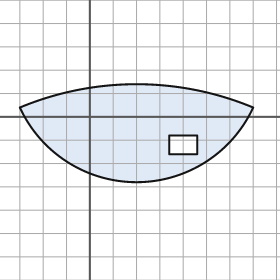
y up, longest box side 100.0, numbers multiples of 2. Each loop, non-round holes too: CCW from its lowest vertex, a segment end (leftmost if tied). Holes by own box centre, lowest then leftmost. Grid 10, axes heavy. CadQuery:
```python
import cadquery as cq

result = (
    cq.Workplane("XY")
    .moveTo(-30.0, 4.0)
    .threePointArc((20.0, -28.0), (70.0, 4.0))
    .threePointArc((20.0, 14.0), (-30.0, 4.0))
    .close()
    .moveTo(34.0, -16.0)
    .lineTo(46.0, -16.0)
    .lineTo(46.0, -8.0)
    .lineTo(34.0, -8.0)
    .close()
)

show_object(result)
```